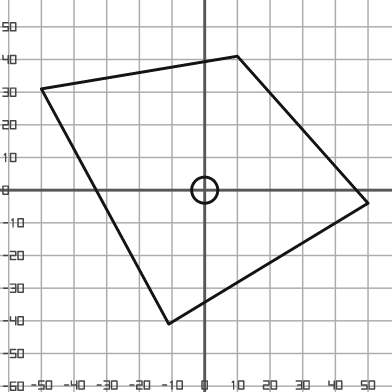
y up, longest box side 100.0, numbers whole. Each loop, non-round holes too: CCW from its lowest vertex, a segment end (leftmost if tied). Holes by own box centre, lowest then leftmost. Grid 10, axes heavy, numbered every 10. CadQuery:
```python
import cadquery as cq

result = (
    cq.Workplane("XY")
    .moveTo(-11.0, -41.0)
    .lineTo(50.0, -4.0)
    .lineTo(10.0, 41.0)
    .lineTo(-50.0, 31.0)
    .close()
    .moveTo(0.0, 0.0)
    .circle(4.0)
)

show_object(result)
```